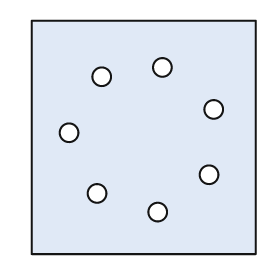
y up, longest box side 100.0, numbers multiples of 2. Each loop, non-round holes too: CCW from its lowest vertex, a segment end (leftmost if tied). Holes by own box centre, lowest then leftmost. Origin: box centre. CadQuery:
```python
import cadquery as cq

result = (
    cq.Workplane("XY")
    .moveTo(-48.0, -50.0)
    .lineTo(48.0, -50.0)
    .lineTo(48.0, 50.0)
    .lineTo(-48.0, 50.0)
    .close()
    .moveTo(6.0, -32.0)
    .circle(4.0)
    .moveTo(-20.0, -24.0)
    .circle(4.0)
    .moveTo(28.0, -16.0)
    .circle(4.0)
    .moveTo(-32.0, 2.0)
    .circle(4.0)
    .moveTo(30.0, 12.0)
    .circle(4.0)
    .moveTo(-18.0, 26.0)
    .circle(4.0)
    .moveTo(8.0, 30.0)
    .circle(4.0)
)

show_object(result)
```